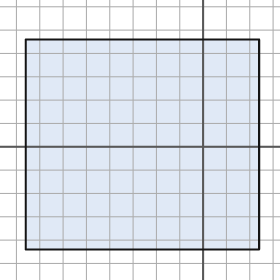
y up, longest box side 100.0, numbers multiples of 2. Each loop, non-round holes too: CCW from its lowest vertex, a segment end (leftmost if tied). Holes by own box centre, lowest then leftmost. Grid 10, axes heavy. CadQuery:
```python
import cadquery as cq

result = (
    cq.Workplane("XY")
    .moveTo(-76.0, -44.0)
    .lineTo(24.0, -44.0)
    .lineTo(24.0, 46.0)
    .lineTo(-76.0, 46.0)
    .close()
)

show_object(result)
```